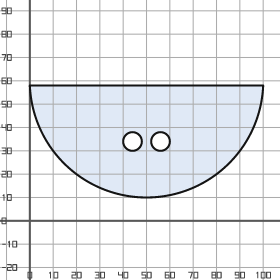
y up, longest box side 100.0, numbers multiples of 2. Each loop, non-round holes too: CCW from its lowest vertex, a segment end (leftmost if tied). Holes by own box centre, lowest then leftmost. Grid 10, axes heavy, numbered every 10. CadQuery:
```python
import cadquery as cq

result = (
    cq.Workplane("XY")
    .moveTo(0.0, 58.0)
    .threePointArc((50.0, 10.0), (100.0, 58.0))
    .close()
    .moveTo(44.0, 34.0)
    .circle(4.0)
    .moveTo(56.0, 34.0)
    .circle(4.0)
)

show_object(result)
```